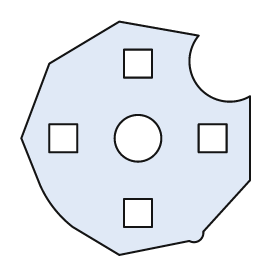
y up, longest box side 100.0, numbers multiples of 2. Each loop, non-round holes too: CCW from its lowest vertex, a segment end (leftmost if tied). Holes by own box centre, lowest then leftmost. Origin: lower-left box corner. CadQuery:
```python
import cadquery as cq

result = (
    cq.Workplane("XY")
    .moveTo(42.0, 0.0)
    .lineTo(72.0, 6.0)
    .threePointArc((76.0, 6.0), (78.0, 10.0))
    .lineTo(98.0, 32.0)
    .lineTo(98.0, 68.0)
    .threePointArc((76.0, 72.0), (76.0, 94.0))
    .lineTo(42.0, 100.0)
    .lineTo(12.0, 82.0)
    .lineTo(0.0, 50.0)
    .lineTo(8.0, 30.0)
    .threePointArc((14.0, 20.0), (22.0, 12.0))
    .close()
    .moveTo(44.0, 12.0)
    .lineTo(56.0, 12.0)
    .lineTo(56.0, 24.0)
    .lineTo(44.0, 24.0)
    .close()
    .moveTo(12.0, 44.0)
    .lineTo(24.0, 44.0)
    .lineTo(24.0, 56.0)
    .lineTo(12.0, 56.0)
    .close()
    .moveTo(50.0, 50.0)
    .circle(10.0)
    .moveTo(76.0, 44.0)
    .lineTo(88.0, 44.0)
    .lineTo(88.0, 56.0)
    .lineTo(76.0, 56.0)
    .close()
    .moveTo(44.0, 76.0)
    .lineTo(56.0, 76.0)
    .lineTo(56.0, 88.0)
    .lineTo(44.0, 88.0)
    .close()
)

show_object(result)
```